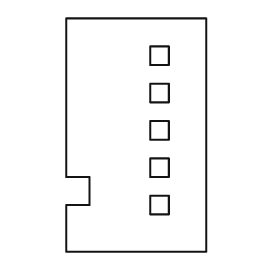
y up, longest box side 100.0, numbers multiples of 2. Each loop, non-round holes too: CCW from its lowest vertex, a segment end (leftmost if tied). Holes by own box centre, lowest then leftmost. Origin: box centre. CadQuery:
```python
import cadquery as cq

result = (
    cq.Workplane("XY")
    .moveTo(-30.0, -50.0)
    .lineTo(30.0, -50.0)
    .lineTo(30.0, 50.0)
    .lineTo(-30.0, 50.0)
    .lineTo(-30.0, -18.0)
    .lineTo(-20.0, -18.0)
    .lineTo(-20.0, -30.0)
    .lineTo(-30.0, -30.0)
    .close()
    .moveTo(6.0, -34.0)
    .lineTo(14.0, -34.0)
    .lineTo(14.0, -26.0)
    .lineTo(6.0, -26.0)
    .close()
    .moveTo(6.0, -18.0)
    .lineTo(14.0, -18.0)
    .lineTo(14.0, -10.0)
    .lineTo(6.0, -10.0)
    .close()
    .moveTo(6.0, -2.0)
    .lineTo(14.0, -2.0)
    .lineTo(14.0, 6.0)
    .lineTo(6.0, 6.0)
    .close()
    .moveTo(6.0, 14.0)
    .lineTo(14.0, 14.0)
    .lineTo(14.0, 22.0)
    .lineTo(6.0, 22.0)
    .close()
    .moveTo(6.0, 30.0)
    .lineTo(14.0, 30.0)
    .lineTo(14.0, 38.0)
    .lineTo(6.0, 38.0)
    .close()
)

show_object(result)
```